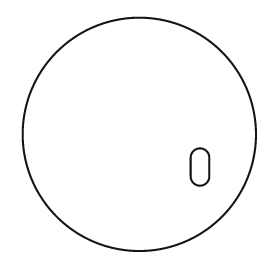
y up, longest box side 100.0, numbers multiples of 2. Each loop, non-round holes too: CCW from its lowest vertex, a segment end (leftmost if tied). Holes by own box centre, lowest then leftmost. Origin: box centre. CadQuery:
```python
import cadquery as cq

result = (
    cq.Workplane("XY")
    .moveTo(0.0, 0.0)
    .circle(50.0)
    .moveTo(22.0, -18.0)
    .threePointArc((26.0, -22.0), (30.0, -18.0))
    .lineTo(30.0, -10.0)
    .threePointArc((26.0, -6.0), (22.0, -10.0))
    .close()
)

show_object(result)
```